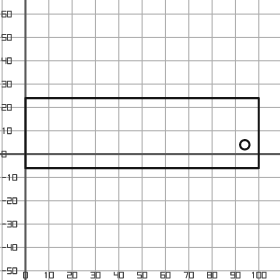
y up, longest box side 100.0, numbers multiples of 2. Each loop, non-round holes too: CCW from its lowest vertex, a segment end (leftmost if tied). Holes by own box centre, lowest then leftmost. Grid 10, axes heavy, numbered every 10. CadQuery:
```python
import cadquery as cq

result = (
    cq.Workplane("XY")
    .moveTo(0.0, -6.0)
    .lineTo(100.0, -6.0)
    .lineTo(100.0, 24.0)
    .lineTo(0.0, 24.0)
    .close()
    .moveTo(94.0, 4.0)
    .circle(2.0)
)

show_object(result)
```